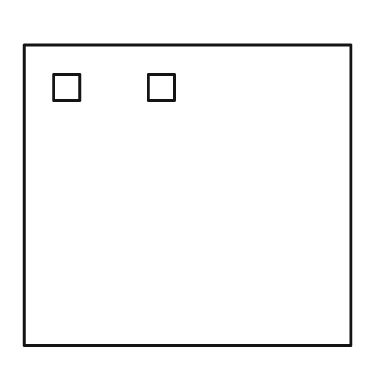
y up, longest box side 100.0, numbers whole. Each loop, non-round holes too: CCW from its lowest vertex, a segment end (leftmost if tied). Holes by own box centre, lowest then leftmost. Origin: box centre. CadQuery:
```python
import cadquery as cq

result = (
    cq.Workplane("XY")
    .moveTo(-50.0, -46.0)
    .lineTo(50.0, -46.0)
    .lineTo(50.0, 46.0)
    .lineTo(-50.0, 46.0)
    .close()
    .moveTo(-41.0, 29.0)
    .lineTo(-33.0, 29.0)
    .lineTo(-33.0, 37.0)
    .lineTo(-41.0, 37.0)
    .close()
    .moveTo(-12.0, 29.0)
    .lineTo(-4.0, 29.0)
    .lineTo(-4.0, 37.0)
    .lineTo(-12.0, 37.0)
    .close()
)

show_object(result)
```